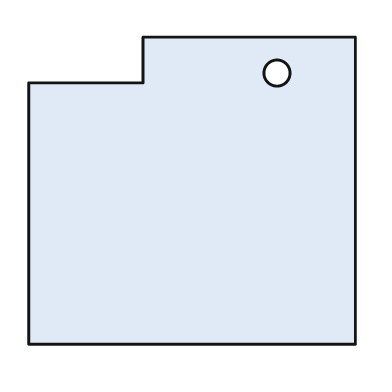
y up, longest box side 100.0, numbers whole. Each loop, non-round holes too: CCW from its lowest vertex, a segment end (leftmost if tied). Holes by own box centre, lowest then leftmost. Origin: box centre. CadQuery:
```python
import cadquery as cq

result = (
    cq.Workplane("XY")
    .moveTo(-50.0, -47.0)
    .lineTo(50.0, -47.0)
    .lineTo(50.0, 47.0)
    .lineTo(-15.0, 47.0)
    .lineTo(-15.0, 33.0)
    .lineTo(-50.0, 33.0)
    .close()
    .moveTo(26.0, 36.0)
    .circle(4.0)
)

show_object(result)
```